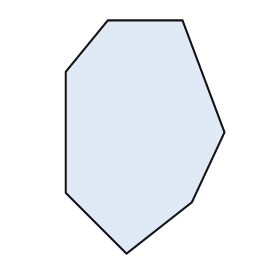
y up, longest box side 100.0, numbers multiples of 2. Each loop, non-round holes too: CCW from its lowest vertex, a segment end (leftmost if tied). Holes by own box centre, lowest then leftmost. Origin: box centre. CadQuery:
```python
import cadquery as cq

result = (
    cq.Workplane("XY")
    .moveTo(-8.0, -50.0)
    .lineTo(20.0, -28.0)
    .lineTo(34.0, 2.0)
    .lineTo(16.0, 50.0)
    .lineTo(-16.0, 50.0)
    .lineTo(-34.0, 28.0)
    .lineTo(-34.0, -24.0)
    .close()
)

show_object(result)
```